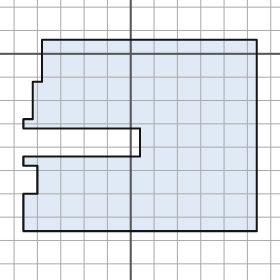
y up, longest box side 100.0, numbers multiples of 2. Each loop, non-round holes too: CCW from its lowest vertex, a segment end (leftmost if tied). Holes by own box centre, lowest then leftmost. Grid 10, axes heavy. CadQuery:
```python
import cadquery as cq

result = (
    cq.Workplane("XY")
    .moveTo(-46.0, -76.0)
    .lineTo(54.0, -76.0)
    .lineTo(54.0, 6.0)
    .lineTo(-38.0, 6.0)
    .lineTo(-38.0, -12.0)
    .lineTo(-42.0, -12.0)
    .lineTo(-42.0, -28.0)
    .lineTo(-46.0, -28.0)
    .lineTo(-46.0, -32.0)
    .lineTo(4.0, -32.0)
    .lineTo(4.0, -44.0)
    .lineTo(-46.0, -44.0)
    .lineTo(-46.0, -48.0)
    .lineTo(-40.0, -48.0)
    .lineTo(-40.0, -60.0)
    .lineTo(-46.0, -60.0)
    .close()
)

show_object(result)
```